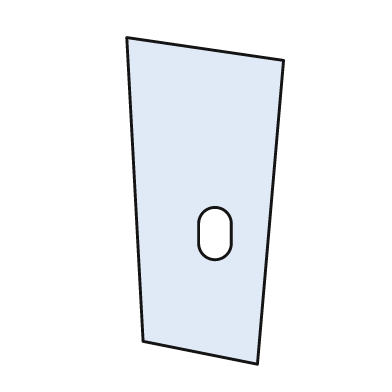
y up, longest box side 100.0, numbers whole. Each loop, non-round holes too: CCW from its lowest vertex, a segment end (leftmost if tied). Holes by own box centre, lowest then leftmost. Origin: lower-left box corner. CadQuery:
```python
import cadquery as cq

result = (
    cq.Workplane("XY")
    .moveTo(40.0, 0.0)
    .lineTo(48.0, 93.0)
    .lineTo(0.0, 100.0)
    .lineTo(5.0, 7.0)
    .close()
    .moveTo(22.0, 37.0)
    .threePointArc((27.0, 32.0), (32.0, 37.0))
    .lineTo(32.0, 43.0)
    .threePointArc((27.0, 48.0), (22.0, 43.0))
    .close()
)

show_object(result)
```